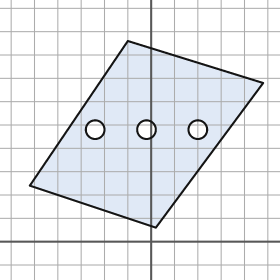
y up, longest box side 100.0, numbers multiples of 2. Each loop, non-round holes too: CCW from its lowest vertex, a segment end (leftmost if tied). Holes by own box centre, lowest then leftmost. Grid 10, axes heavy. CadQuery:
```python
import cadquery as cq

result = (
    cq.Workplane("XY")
    .moveTo(2.0, 6.0)
    .lineTo(48.0, 68.0)
    .lineTo(-10.0, 86.0)
    .lineTo(-52.0, 24.0)
    .close()
    .moveTo(-24.0, 48.0)
    .circle(4.0)
    .moveTo(-2.0, 48.0)
    .circle(4.0)
    .moveTo(20.0, 48.0)
    .circle(4.0)
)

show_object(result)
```